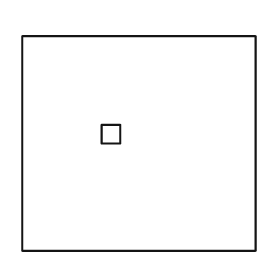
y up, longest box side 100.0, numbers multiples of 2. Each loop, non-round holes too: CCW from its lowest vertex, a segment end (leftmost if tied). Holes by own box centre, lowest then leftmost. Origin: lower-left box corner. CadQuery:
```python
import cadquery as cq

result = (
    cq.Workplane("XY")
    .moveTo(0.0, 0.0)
    .lineTo(100.0, 0.0)
    .lineTo(100.0, 92.0)
    .lineTo(0.0, 92.0)
    .close()
    .moveTo(34.0, 46.0)
    .lineTo(42.0, 46.0)
    .lineTo(42.0, 54.0)
    .lineTo(34.0, 54.0)
    .close()
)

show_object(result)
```